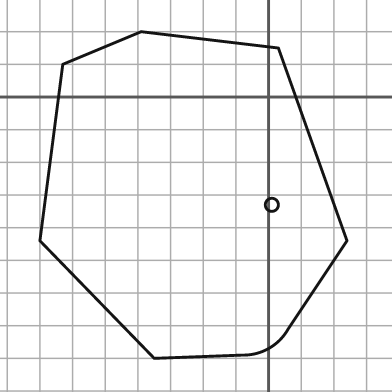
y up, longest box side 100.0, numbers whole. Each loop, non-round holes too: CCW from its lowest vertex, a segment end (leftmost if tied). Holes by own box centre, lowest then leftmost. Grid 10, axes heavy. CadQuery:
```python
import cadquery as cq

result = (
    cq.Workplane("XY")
    .moveTo(-35.0, -80.0)
    .lineTo(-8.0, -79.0)
    .threePointArc((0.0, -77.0), (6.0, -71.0))
    .lineTo(24.0, -44.0)
    .lineTo(3.0, 15.0)
    .lineTo(-39.0, 20.0)
    .lineTo(-63.0, 10.0)
    .lineTo(-70.0, -44.0)
    .close()
    .moveTo(1.0, -33.0)
    .circle(2.0)
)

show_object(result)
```